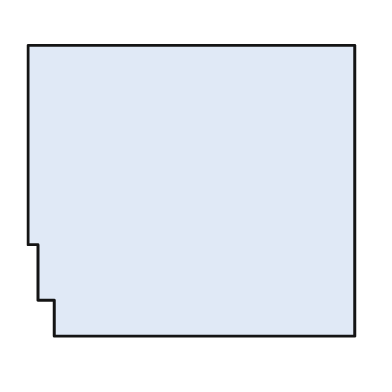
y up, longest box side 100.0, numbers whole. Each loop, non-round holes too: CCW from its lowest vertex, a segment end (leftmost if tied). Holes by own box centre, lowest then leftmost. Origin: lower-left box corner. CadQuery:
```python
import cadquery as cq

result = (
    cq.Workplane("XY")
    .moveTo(8.0, 0.0)
    .lineTo(100.0, 0.0)
    .lineTo(100.0, 89.0)
    .lineTo(0.0, 89.0)
    .lineTo(0.0, 28.0)
    .lineTo(3.0, 28.0)
    .lineTo(3.0, 11.0)
    .lineTo(8.0, 11.0)
    .close()
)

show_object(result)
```